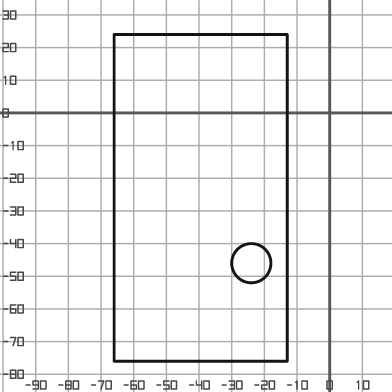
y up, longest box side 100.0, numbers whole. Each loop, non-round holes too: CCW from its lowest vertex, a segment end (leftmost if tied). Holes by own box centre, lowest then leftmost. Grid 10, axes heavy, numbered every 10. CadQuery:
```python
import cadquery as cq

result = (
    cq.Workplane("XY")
    .moveTo(-66.0, -76.0)
    .lineTo(-13.0, -76.0)
    .lineTo(-13.0, 24.0)
    .lineTo(-66.0, 24.0)
    .close()
    .moveTo(-24.0, -46.0)
    .circle(6.0)
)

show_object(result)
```